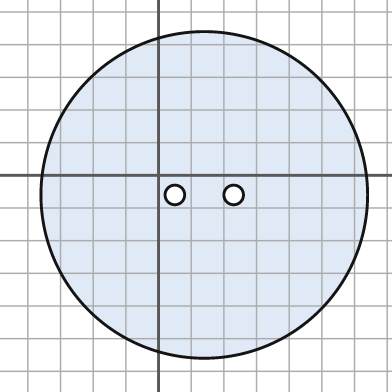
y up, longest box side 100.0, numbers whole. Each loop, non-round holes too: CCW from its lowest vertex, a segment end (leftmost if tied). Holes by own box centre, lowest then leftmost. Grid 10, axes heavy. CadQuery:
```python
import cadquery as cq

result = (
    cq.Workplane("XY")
    .moveTo(14.0, -6.0)
    .circle(50.0)
    .moveTo(5.0, -6.0)
    .circle(3.0)
    .moveTo(23.0, -6.0)
    .circle(3.0)
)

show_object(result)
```